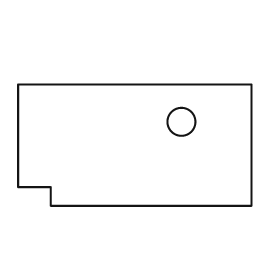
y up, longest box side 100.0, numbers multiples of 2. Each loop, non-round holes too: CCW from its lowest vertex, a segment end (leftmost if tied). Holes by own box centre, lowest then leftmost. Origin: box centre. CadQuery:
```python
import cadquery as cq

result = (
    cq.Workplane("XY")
    .moveTo(-36.0, -26.0)
    .lineTo(50.0, -26.0)
    .lineTo(50.0, 26.0)
    .lineTo(-50.0, 26.0)
    .lineTo(-50.0, -18.0)
    .lineTo(-36.0, -18.0)
    .close()
    .moveTo(20.0, 10.0)
    .circle(6.0)
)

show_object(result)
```